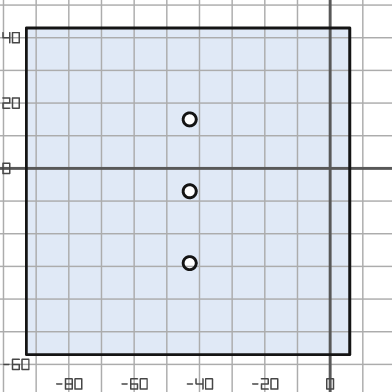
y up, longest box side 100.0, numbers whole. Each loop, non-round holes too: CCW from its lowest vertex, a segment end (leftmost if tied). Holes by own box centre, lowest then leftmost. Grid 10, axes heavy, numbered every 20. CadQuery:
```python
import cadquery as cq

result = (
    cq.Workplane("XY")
    .moveTo(-93.0, -57.0)
    .lineTo(6.0, -57.0)
    .lineTo(6.0, 43.0)
    .lineTo(-93.0, 43.0)
    .close()
    .moveTo(-43.0, -29.0)
    .circle(2.0)
    .moveTo(-43.0, -7.0)
    .circle(2.0)
    .moveTo(-43.0, 15.0)
    .circle(2.0)
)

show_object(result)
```